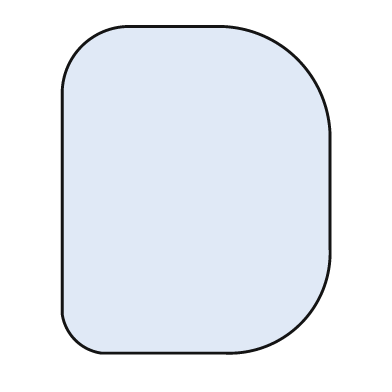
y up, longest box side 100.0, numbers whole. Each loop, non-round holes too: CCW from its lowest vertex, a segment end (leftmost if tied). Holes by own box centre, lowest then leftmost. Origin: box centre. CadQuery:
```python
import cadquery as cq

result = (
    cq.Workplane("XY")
    .moveTo(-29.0, -50.0)
    .lineTo(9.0, -50.0)
    .threePointArc((32.0, -41.0), (41.0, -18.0))
    .lineTo(41.0, 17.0)
    .threePointArc((31.0, 40.0), (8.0, 50.0))
    .lineTo(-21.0, 50.0)
    .threePointArc((-35.0, 44.0), (-41.0, 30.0))
    .lineTo(-41.0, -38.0)
    .threePointArc((-37.0, -46.0), (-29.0, -50.0))
    .close()
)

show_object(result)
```